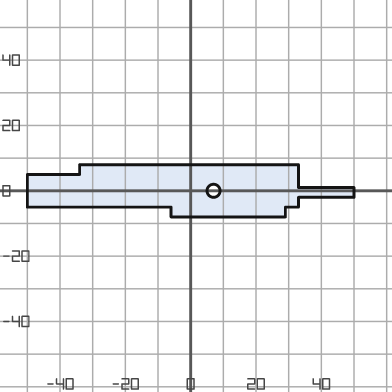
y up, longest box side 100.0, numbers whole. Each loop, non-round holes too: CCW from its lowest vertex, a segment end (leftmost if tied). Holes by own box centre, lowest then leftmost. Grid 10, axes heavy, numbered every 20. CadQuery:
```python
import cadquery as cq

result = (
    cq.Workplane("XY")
    .moveTo(-6.0, -8.0)
    .lineTo(29.0, -8.0)
    .lineTo(29.0, -5.0)
    .lineTo(33.0, -5.0)
    .lineTo(33.0, -2.0)
    .lineTo(50.0, -2.0)
    .lineTo(50.0, 1.0)
    .lineTo(33.0, 1.0)
    .lineTo(33.0, 8.0)
    .lineTo(-34.0, 8.0)
    .lineTo(-34.0, 5.0)
    .lineTo(-50.0, 5.0)
    .lineTo(-50.0, -5.0)
    .lineTo(-6.0, -5.0)
    .close()
    .moveTo(7.0, 0.0)
    .circle(2.0)
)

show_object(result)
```